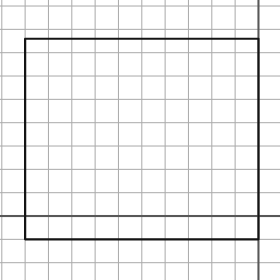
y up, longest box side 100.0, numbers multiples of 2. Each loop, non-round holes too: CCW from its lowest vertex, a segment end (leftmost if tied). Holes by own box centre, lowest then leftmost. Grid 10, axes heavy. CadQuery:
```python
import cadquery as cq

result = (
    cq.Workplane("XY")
    .moveTo(-100.0, -10.0)
    .lineTo(0.0, -10.0)
    .lineTo(0.0, 76.0)
    .lineTo(-100.0, 76.0)
    .close()
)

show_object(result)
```